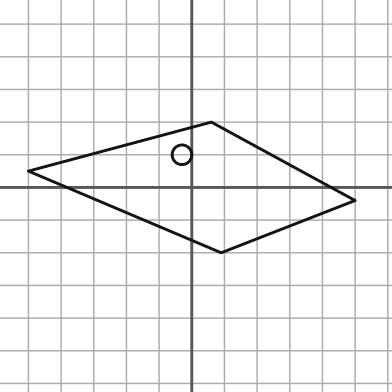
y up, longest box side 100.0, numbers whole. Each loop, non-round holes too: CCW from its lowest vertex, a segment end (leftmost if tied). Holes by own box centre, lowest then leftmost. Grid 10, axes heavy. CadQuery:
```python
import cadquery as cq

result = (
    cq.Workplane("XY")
    .moveTo(9.0, -20.0)
    .lineTo(50.0, -4.0)
    .lineTo(6.0, 20.0)
    .lineTo(-50.0, 5.0)
    .close()
    .moveTo(-3.0, 10.0)
    .circle(3.0)
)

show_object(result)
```